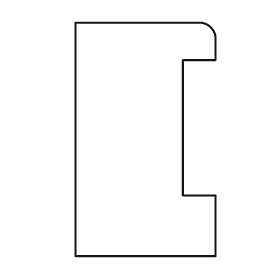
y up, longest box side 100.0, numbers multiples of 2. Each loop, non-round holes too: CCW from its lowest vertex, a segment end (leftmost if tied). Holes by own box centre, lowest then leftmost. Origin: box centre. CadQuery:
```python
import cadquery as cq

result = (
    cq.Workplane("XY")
    .moveTo(-30.0, -50.0)
    .lineTo(30.0, -50.0)
    .lineTo(30.0, -24.0)
    .lineTo(16.0, -24.0)
    .lineTo(16.0, 34.0)
    .lineTo(30.0, 34.0)
    .lineTo(30.0, 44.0)
    .threePointArc((28.0, 48.0), (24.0, 50.0))
    .lineTo(-30.0, 50.0)
    .close()
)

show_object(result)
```